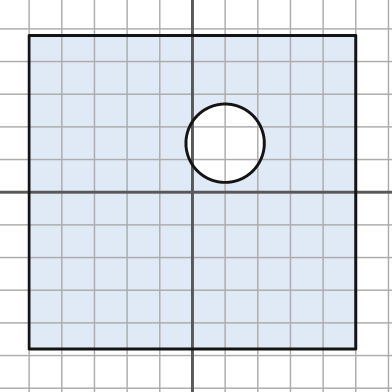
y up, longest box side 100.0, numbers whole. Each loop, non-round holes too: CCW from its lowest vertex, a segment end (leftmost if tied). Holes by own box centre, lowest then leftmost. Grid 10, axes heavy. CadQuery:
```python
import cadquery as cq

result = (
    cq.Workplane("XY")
    .moveTo(-50.0, -48.0)
    .lineTo(50.0, -48.0)
    .lineTo(50.0, 48.0)
    .lineTo(-50.0, 48.0)
    .close()
    .moveTo(10.0, 15.0)
    .circle(12.0)
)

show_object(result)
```